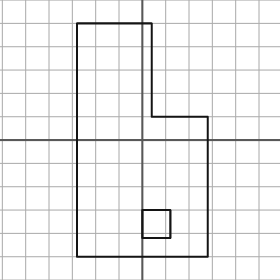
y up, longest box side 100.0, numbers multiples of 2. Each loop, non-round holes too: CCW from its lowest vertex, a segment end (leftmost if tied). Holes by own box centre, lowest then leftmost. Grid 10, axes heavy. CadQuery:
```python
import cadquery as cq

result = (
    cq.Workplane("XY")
    .moveTo(-28.0, -50.0)
    .lineTo(28.0, -50.0)
    .lineTo(28.0, 10.0)
    .lineTo(4.0, 10.0)
    .lineTo(4.0, 50.0)
    .lineTo(-28.0, 50.0)
    .close()
    .moveTo(0.0, -42.0)
    .lineTo(12.0, -42.0)
    .lineTo(12.0, -30.0)
    .lineTo(0.0, -30.0)
    .close()
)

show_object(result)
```